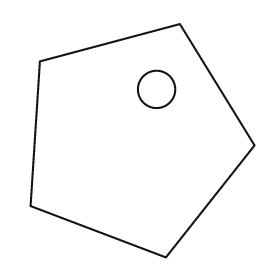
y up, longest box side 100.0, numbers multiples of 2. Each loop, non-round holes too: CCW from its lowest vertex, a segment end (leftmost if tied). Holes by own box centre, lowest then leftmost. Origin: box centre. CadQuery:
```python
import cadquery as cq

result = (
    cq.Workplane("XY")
    .moveTo(10.0, -50.0)
    .lineTo(48.0, -2.0)
    .lineTo(16.0, 50.0)
    .lineTo(-44.0, 34.0)
    .lineTo(-48.0, -28.0)
    .close()
    .moveTo(6.0, 22.0)
    .circle(8.0)
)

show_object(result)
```